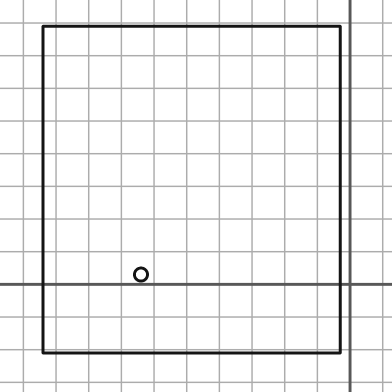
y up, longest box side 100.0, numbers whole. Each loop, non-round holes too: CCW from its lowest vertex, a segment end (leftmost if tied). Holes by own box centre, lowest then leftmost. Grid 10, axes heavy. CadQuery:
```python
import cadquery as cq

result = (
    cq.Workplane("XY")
    .moveTo(-94.0, -21.0)
    .lineTo(-3.0, -21.0)
    .lineTo(-3.0, 79.0)
    .lineTo(-94.0, 79.0)
    .close()
    .moveTo(-64.0, 3.0)
    .circle(2.0)
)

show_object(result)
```